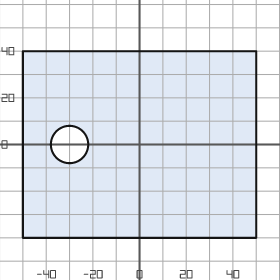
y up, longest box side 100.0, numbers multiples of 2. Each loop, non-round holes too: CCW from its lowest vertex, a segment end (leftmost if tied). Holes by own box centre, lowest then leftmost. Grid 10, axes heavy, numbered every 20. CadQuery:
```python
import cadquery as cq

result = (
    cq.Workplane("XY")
    .moveTo(-50.0, -40.0)
    .lineTo(50.0, -40.0)
    .lineTo(50.0, 40.0)
    .lineTo(-50.0, 40.0)
    .close()
    .moveTo(-30.0, 0.0)
    .circle(8.0)
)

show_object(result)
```